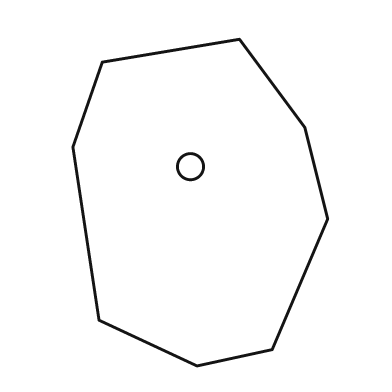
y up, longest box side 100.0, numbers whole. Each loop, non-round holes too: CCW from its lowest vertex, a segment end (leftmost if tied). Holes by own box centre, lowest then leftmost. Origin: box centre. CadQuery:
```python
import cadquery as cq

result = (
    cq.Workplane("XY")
    .moveTo(-1.0, -50.0)
    .lineTo(22.0, -45.0)
    .lineTo(39.0, -5.0)
    .lineTo(32.0, 23.0)
    .lineTo(12.0, 50.0)
    .lineTo(-30.0, 43.0)
    .lineTo(-39.0, 17.0)
    .lineTo(-31.0, -36.0)
    .close()
    .moveTo(-3.0, 11.0)
    .circle(4.0)
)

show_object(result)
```